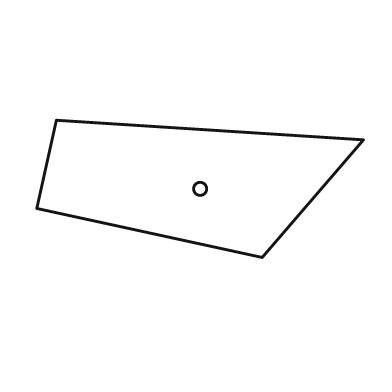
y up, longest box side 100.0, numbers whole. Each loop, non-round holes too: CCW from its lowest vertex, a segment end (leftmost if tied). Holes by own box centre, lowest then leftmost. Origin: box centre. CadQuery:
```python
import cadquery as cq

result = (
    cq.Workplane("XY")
    .moveTo(19.0, -21.0)
    .lineTo(50.0, 15.0)
    .lineTo(-44.0, 21.0)
    .lineTo(-50.0, -6.0)
    .close()
    .moveTo(0.0, 0.0)
    .circle(2.0)
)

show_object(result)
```